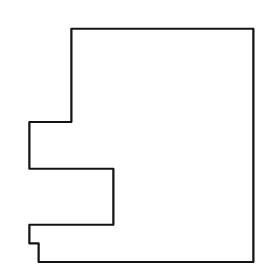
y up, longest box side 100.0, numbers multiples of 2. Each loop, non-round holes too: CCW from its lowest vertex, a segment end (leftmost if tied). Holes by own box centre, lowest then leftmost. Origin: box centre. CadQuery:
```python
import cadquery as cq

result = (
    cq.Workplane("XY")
    .moveTo(-44.0, -50.0)
    .lineTo(48.0, -50.0)
    .lineTo(48.0, 50.0)
    .lineTo(-30.0, 50.0)
    .lineTo(-30.0, 10.0)
    .lineTo(-48.0, 10.0)
    .lineTo(-48.0, -10.0)
    .lineTo(-12.0, -10.0)
    .lineTo(-12.0, -34.0)
    .lineTo(-48.0, -34.0)
    .lineTo(-48.0, -42.0)
    .lineTo(-44.0, -42.0)
    .close()
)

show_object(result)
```